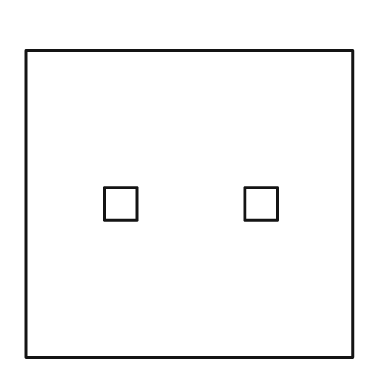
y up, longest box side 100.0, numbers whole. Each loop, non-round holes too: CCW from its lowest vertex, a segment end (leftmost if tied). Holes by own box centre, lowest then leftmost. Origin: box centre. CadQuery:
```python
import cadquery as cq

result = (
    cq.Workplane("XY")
    .moveTo(-50.0, -47.0)
    .lineTo(50.0, -47.0)
    .lineTo(50.0, 47.0)
    .lineTo(-50.0, 47.0)
    .close()
    .moveTo(-26.0, -5.0)
    .lineTo(-16.0, -5.0)
    .lineTo(-16.0, 5.0)
    .lineTo(-26.0, 5.0)
    .close()
    .moveTo(17.0, -5.0)
    .lineTo(27.0, -5.0)
    .lineTo(27.0, 5.0)
    .lineTo(17.0, 5.0)
    .close()
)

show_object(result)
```